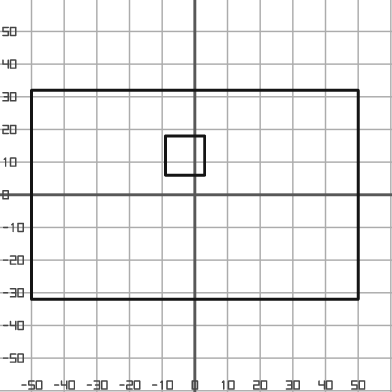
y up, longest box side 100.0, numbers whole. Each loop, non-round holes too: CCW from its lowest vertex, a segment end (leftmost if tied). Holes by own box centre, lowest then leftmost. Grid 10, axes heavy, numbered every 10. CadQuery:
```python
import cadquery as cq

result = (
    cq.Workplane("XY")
    .moveTo(-50.0, -32.0)
    .lineTo(50.0, -32.0)
    .lineTo(50.0, 32.0)
    .lineTo(-50.0, 32.0)
    .close()
    .moveTo(-9.0, 6.0)
    .lineTo(3.0, 6.0)
    .lineTo(3.0, 18.0)
    .lineTo(-9.0, 18.0)
    .close()
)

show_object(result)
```